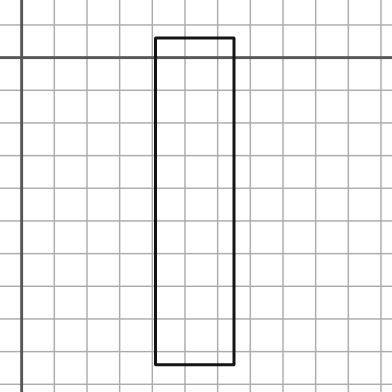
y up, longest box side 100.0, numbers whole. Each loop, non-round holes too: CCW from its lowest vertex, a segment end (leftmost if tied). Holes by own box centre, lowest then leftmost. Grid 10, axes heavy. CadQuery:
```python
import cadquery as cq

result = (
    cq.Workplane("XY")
    .moveTo(41.0, -94.0)
    .lineTo(65.0, -94.0)
    .lineTo(65.0, 6.0)
    .lineTo(41.0, 6.0)
    .close()
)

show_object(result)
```